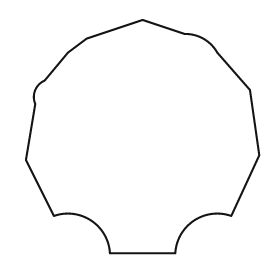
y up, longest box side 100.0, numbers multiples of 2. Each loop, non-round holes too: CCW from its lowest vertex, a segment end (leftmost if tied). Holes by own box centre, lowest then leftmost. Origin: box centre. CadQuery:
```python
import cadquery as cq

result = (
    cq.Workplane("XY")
    .moveTo(-14.0, -50.0)
    .lineTo(14.0, -50.0)
    .threePointArc((22.0, -36.0), (38.0, -34.0))
    .lineTo(50.0, -8.0)
    .lineTo(46.0, 20.0)
    .lineTo(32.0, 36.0)
    .threePointArc((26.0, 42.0), (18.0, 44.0))
    .lineTo(0.0, 50.0)
    .lineTo(-24.0, 42.0)
    .lineTo(-32.0, 36.0)
    .lineTo(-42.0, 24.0)
    .threePointArc((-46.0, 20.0), (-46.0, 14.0))
    .lineTo(-50.0, -10.0)
    .lineTo(-38.0, -34.0)
    .threePointArc((-22.0, -36.0), (-14.0, -50.0))
    .close()
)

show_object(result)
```